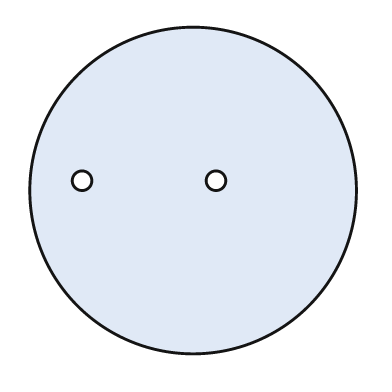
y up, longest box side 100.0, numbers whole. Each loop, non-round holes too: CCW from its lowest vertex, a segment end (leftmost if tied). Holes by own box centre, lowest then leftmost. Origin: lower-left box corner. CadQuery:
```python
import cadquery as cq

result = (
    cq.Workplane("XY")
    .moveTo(50.0, 50.0)
    .circle(50.0)
    .moveTo(16.0, 53.0)
    .circle(3.0)
    .moveTo(57.0, 53.0)
    .circle(3.0)
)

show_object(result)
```